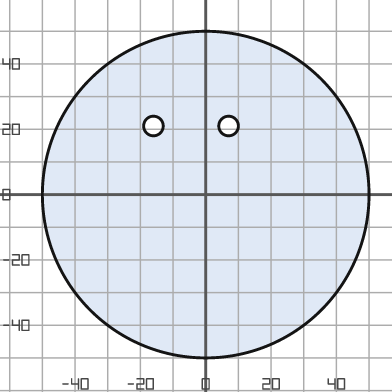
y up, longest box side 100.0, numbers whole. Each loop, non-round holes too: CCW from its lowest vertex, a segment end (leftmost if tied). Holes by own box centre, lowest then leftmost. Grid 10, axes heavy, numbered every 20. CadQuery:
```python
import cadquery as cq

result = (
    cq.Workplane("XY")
    .moveTo(0.0, 0.0)
    .circle(50.0)
    .moveTo(-16.0, 21.0)
    .circle(3.0)
    .moveTo(7.0, 21.0)
    .circle(3.0)
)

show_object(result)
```